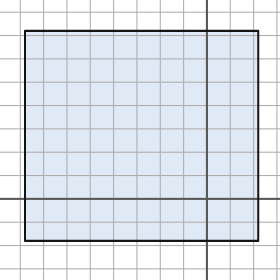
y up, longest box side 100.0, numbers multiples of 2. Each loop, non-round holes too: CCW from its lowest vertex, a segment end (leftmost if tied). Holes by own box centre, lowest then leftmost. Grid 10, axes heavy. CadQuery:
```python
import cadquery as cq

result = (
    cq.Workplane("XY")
    .moveTo(-78.0, -18.0)
    .lineTo(22.0, -18.0)
    .lineTo(22.0, 72.0)
    .lineTo(-78.0, 72.0)
    .close()
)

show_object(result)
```